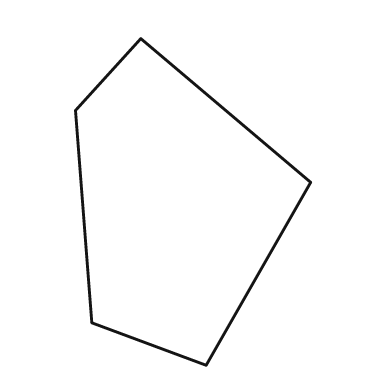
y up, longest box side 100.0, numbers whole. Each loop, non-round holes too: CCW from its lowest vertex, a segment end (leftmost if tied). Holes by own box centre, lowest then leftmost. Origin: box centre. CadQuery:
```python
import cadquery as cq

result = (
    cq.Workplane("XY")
    .moveTo(4.0, -50.0)
    .lineTo(36.0, 6.0)
    .lineTo(-16.0, 50.0)
    .lineTo(-36.0, 28.0)
    .lineTo(-31.0, -37.0)
    .close()
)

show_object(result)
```